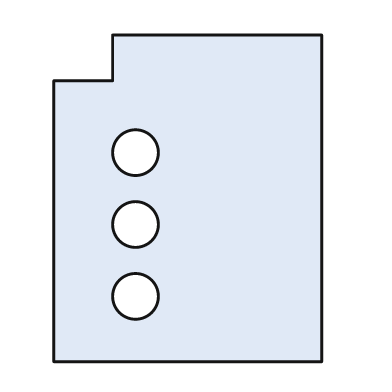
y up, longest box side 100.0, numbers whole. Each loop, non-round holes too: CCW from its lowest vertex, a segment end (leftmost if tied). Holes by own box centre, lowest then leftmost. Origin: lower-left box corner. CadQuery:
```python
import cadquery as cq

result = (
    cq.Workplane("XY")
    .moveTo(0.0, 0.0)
    .lineTo(82.0, 0.0)
    .lineTo(82.0, 100.0)
    .lineTo(18.0, 100.0)
    .lineTo(18.0, 86.0)
    .lineTo(0.0, 86.0)
    .close()
    .moveTo(25.0, 20.0)
    .circle(7.0)
    .moveTo(25.0, 42.0)
    .circle(7.0)
    .moveTo(25.0, 64.0)
    .circle(7.0)
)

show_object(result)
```